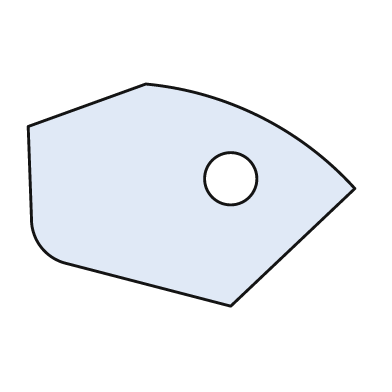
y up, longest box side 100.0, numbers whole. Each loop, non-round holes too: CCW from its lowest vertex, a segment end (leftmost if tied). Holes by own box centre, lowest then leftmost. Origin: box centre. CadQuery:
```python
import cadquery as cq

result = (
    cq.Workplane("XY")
    .moveTo(12.0, -34.0)
    .lineTo(50.0, 2.0)
    .threePointArc((21.0, 24.0), (-14.0, 34.0))
    .lineTo(-50.0, 21.0)
    .lineTo(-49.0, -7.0)
    .threePointArc((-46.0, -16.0), (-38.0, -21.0))
    .close()
    .moveTo(12.0, 5.0)
    .circle(8.0)
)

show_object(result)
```